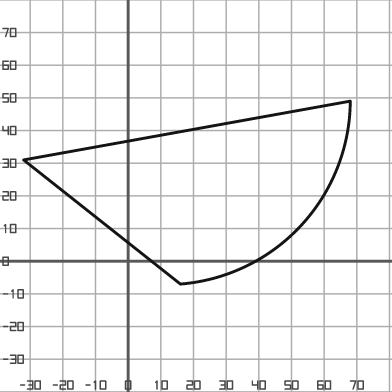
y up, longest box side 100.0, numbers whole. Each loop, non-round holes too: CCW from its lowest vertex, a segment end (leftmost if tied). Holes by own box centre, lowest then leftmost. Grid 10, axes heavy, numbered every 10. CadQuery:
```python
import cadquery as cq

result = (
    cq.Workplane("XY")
    .moveTo(16.0, -7.0)
    .threePointArc((53.0, 11.0), (68.0, 49.0))
    .lineTo(-32.0, 31.0)
    .close()
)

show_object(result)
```